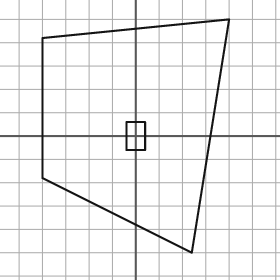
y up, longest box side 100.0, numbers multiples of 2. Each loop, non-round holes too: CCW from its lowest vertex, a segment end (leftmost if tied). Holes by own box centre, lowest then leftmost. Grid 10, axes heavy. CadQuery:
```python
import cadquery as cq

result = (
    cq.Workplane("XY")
    .moveTo(24.0, -50.0)
    .lineTo(40.0, 50.0)
    .lineTo(-40.0, 42.0)
    .lineTo(-40.0, -18.0)
    .close()
    .moveTo(-4.0, -6.0)
    .lineTo(4.0, -6.0)
    .lineTo(4.0, 6.0)
    .lineTo(-4.0, 6.0)
    .close()
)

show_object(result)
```